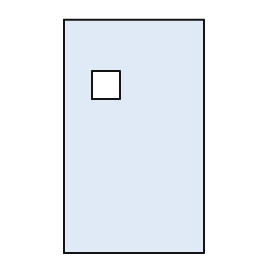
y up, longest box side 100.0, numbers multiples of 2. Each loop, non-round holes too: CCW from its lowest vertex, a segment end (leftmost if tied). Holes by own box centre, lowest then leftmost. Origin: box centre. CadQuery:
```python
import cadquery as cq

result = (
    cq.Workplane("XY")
    .moveTo(-30.0, -50.0)
    .lineTo(30.0, -50.0)
    .lineTo(30.0, 50.0)
    .lineTo(-30.0, 50.0)
    .close()
    .moveTo(-18.0, 16.0)
    .lineTo(-6.0, 16.0)
    .lineTo(-6.0, 28.0)
    .lineTo(-18.0, 28.0)
    .close()
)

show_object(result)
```